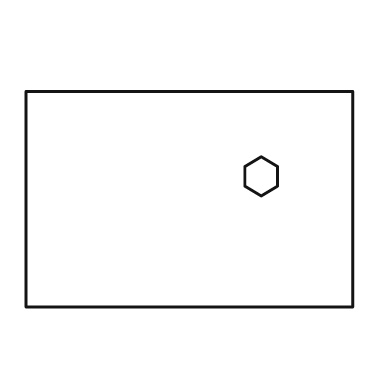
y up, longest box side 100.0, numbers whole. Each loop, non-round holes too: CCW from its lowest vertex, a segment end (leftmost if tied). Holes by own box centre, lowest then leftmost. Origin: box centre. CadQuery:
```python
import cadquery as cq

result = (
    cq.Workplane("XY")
    .moveTo(-50.0, -33.0)
    .lineTo(50.0, -33.0)
    .lineTo(50.0, 33.0)
    .lineTo(-50.0, 33.0)
    .close()
    .moveTo(22.0, 1.0)
    .lineTo(27.0, 4.0)
    .lineTo(27.0, 10.0)
    .lineTo(22.0, 13.0)
    .lineTo(17.0, 10.0)
    .lineTo(17.0, 4.0)
    .close()
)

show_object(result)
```